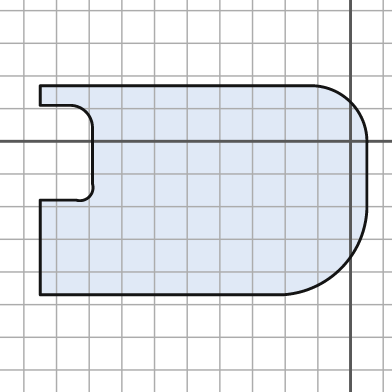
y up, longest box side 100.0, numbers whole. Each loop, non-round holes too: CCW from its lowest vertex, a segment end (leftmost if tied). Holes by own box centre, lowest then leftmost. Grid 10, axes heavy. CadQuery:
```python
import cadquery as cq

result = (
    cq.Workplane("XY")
    .moveTo(-95.0, -47.0)
    .lineTo(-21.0, -47.0)
    .threePointArc((-3.0, -39.0), (5.0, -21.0))
    .lineTo(5.0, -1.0)
    .threePointArc((0.0, 12.0), (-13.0, 17.0))
    .lineTo(-95.0, 17.0)
    .lineTo(-95.0, 11.0)
    .lineTo(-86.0, 11.0)
    .threePointArc((-81.0, 9.0), (-79.0, 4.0))
    .lineTo(-79.0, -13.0)
    .threePointArc((-80.0, -17.0), (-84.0, -18.0))
    .lineTo(-95.0, -18.0)
    .close()
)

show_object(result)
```